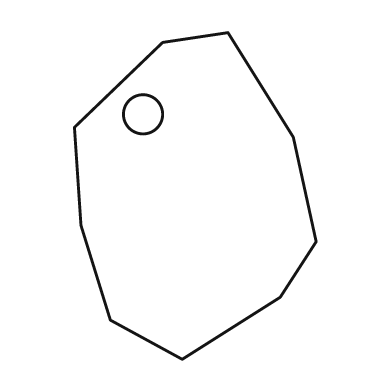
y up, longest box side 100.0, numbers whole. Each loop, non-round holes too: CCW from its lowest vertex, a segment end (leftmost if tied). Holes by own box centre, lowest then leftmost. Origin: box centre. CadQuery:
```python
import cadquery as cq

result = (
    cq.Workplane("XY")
    .moveTo(-4.0, -50.0)
    .lineTo(26.0, -31.0)
    .lineTo(37.0, -14.0)
    .lineTo(30.0, 18.0)
    .lineTo(10.0, 50.0)
    .lineTo(-10.0, 47.0)
    .lineTo(-37.0, 21.0)
    .lineTo(-35.0, -9.0)
    .lineTo(-26.0, -38.0)
    .close()
    .moveTo(-16.0, 25.0)
    .circle(6.0)
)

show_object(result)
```